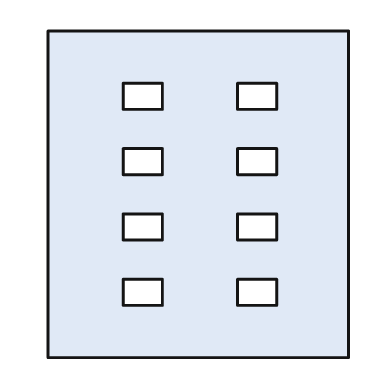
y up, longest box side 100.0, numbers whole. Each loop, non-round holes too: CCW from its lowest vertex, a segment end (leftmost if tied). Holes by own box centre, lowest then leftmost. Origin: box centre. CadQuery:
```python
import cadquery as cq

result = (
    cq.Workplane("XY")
    .moveTo(-46.0, -50.0)
    .lineTo(46.0, -50.0)
    .lineTo(46.0, 50.0)
    .lineTo(-46.0, 50.0)
    .close()
    .moveTo(-23.0, -34.0)
    .lineTo(-11.0, -34.0)
    .lineTo(-11.0, -26.0)
    .lineTo(-23.0, -26.0)
    .close()
    .moveTo(12.0, -34.0)
    .lineTo(24.0, -34.0)
    .lineTo(24.0, -26.0)
    .lineTo(12.0, -26.0)
    .close()
    .moveTo(-23.0, -14.0)
    .lineTo(-11.0, -14.0)
    .lineTo(-11.0, -6.0)
    .lineTo(-23.0, -6.0)
    .close()
    .moveTo(12.0, -14.0)
    .lineTo(24.0, -14.0)
    .lineTo(24.0, -6.0)
    .lineTo(12.0, -6.0)
    .close()
    .moveTo(-23.0, 6.0)
    .lineTo(-11.0, 6.0)
    .lineTo(-11.0, 14.0)
    .lineTo(-23.0, 14.0)
    .close()
    .moveTo(12.0, 6.0)
    .lineTo(24.0, 6.0)
    .lineTo(24.0, 14.0)
    .lineTo(12.0, 14.0)
    .close()
    .moveTo(-23.0, 26.0)
    .lineTo(-11.0, 26.0)
    .lineTo(-11.0, 34.0)
    .lineTo(-23.0, 34.0)
    .close()
    .moveTo(12.0, 26.0)
    .lineTo(24.0, 26.0)
    .lineTo(24.0, 34.0)
    .lineTo(12.0, 34.0)
    .close()
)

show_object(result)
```